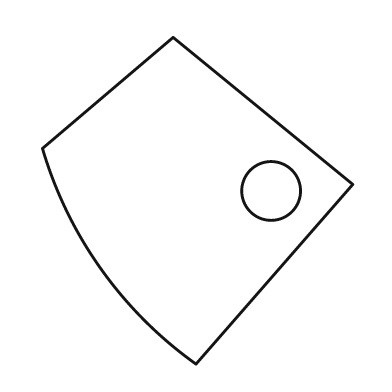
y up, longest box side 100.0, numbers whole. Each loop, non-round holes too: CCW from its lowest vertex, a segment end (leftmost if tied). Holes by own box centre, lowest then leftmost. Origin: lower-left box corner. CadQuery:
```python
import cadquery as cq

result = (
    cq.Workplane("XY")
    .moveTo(47.0, 0.0)
    .lineTo(95.0, 55.0)
    .lineTo(40.0, 100.0)
    .lineTo(0.0, 66.0)
    .threePointArc((18.0, 29.0), (47.0, 0.0))
    .close()
    .moveTo(70.0, 53.0)
    .circle(9.0)
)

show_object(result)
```